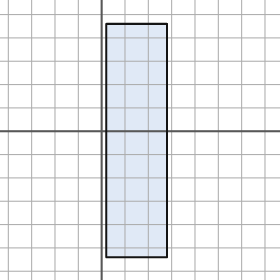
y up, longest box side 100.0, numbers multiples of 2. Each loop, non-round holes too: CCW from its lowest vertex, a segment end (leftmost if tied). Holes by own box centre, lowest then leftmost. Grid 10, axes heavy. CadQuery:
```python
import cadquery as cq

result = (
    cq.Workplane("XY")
    .moveTo(2.0, -54.0)
    .lineTo(28.0, -54.0)
    .lineTo(28.0, 46.0)
    .lineTo(2.0, 46.0)
    .close()
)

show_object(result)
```